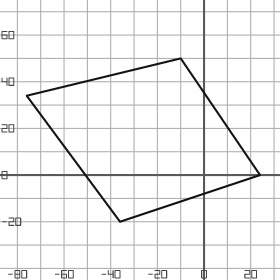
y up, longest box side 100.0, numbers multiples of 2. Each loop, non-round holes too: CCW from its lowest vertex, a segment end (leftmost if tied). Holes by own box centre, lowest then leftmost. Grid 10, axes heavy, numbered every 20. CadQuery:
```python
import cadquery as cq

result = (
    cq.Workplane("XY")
    .moveTo(-36.0, -20.0)
    .lineTo(24.0, 0.0)
    .lineTo(-10.0, 50.0)
    .lineTo(-76.0, 34.0)
    .close()
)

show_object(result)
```